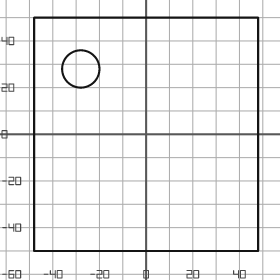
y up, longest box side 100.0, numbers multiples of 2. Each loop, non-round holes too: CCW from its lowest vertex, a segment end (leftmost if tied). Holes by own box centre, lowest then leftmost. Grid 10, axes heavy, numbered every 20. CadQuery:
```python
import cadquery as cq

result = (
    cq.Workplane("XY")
    .moveTo(-48.0, -50.0)
    .lineTo(48.0, -50.0)
    .lineTo(48.0, 50.0)
    .lineTo(-48.0, 50.0)
    .close()
    .moveTo(-28.0, 28.0)
    .circle(8.0)
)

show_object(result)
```